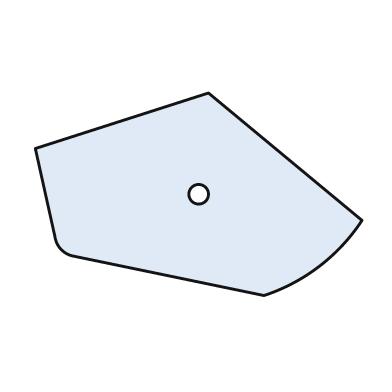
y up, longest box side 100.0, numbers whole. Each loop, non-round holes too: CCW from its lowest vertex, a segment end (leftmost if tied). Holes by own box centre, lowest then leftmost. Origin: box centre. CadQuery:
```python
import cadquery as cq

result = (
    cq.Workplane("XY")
    .moveTo(20.0, -31.0)
    .threePointArc((37.0, -22.0), (50.0, -8.0))
    .lineTo(3.0, 31.0)
    .lineTo(-50.0, 14.0)
    .lineTo(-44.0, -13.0)
    .threePointArc((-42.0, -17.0), (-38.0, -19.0))
    .close()
    .moveTo(0.0, 0.0)
    .circle(3.0)
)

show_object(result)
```